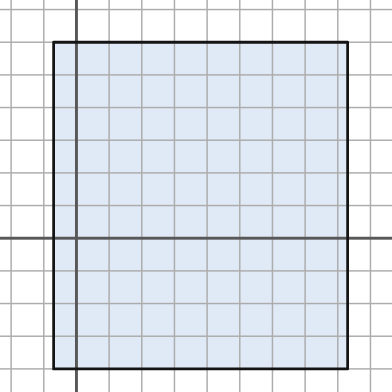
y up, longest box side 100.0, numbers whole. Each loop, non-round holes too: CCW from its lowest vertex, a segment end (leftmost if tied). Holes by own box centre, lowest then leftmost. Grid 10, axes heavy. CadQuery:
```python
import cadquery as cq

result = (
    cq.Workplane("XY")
    .moveTo(-7.0, -40.0)
    .lineTo(83.0, -40.0)
    .lineTo(83.0, 60.0)
    .lineTo(-7.0, 60.0)
    .close()
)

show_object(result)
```